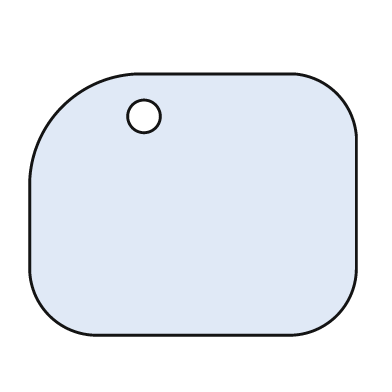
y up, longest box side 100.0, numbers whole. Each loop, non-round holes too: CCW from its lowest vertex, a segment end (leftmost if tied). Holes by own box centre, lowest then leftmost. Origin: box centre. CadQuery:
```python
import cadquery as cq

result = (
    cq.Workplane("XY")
    .moveTo(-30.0, -40.0)
    .lineTo(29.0, -40.0)
    .threePointArc((44.0, -34.0), (50.0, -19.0))
    .lineTo(50.0, 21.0)
    .threePointArc((44.0, 34.0), (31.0, 40.0))
    .lineTo(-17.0, 40.0)
    .threePointArc((-40.0, 30.0), (-50.0, 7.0))
    .lineTo(-50.0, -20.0)
    .threePointArc((-44.0, -34.0), (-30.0, -40.0))
    .close()
    .moveTo(-15.0, 27.0)
    .circle(5.0)
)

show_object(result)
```